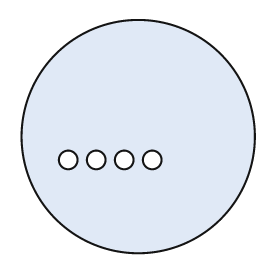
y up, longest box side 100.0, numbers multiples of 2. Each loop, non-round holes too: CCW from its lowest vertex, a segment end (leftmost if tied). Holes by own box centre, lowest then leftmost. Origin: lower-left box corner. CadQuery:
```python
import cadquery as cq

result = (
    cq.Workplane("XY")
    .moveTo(50.0, 50.0)
    .circle(50.0)
    .moveTo(20.0, 40.0)
    .circle(4.0)
    .moveTo(32.0, 40.0)
    .circle(4.0)
    .moveTo(44.0, 40.0)
    .circle(4.0)
    .moveTo(56.0, 40.0)
    .circle(4.0)
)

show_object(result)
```